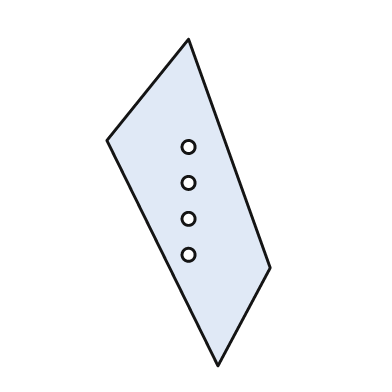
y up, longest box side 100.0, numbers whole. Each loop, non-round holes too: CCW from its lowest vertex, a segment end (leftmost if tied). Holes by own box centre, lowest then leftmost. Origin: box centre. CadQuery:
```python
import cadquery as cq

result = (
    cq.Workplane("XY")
    .moveTo(9.0, -50.0)
    .lineTo(25.0, -20.0)
    .lineTo(0.0, 50.0)
    .lineTo(-25.0, 19.0)
    .close()
    .moveTo(0.0, -16.0)
    .circle(2.0)
    .moveTo(0.0, -5.0)
    .circle(2.0)
    .moveTo(0.0, 6.0)
    .circle(2.0)
    .moveTo(0.0, 17.0)
    .circle(2.0)
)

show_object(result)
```